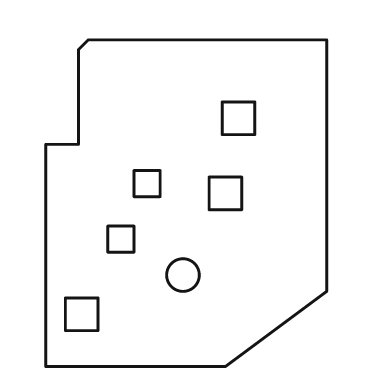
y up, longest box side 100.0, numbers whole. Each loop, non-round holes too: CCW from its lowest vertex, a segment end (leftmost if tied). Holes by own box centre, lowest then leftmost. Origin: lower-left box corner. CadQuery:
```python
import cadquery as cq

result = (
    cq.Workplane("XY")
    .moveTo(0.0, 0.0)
    .lineTo(55.0, 0.0)
    .lineTo(86.0, 23.0)
    .lineTo(86.0, 100.0)
    .lineTo(13.0, 100.0)
    .lineTo(10.0, 97.0)
    .lineTo(10.0, 68.0)
    .lineTo(0.0, 68.0)
    .close()
    .moveTo(6.0, 11.0)
    .lineTo(16.0, 11.0)
    .lineTo(16.0, 21.0)
    .lineTo(6.0, 21.0)
    .close()
    .moveTo(42.0, 28.0)
    .circle(5.0)
    .moveTo(19.0, 35.0)
    .lineTo(27.0, 35.0)
    .lineTo(27.0, 43.0)
    .lineTo(19.0, 43.0)
    .close()
    .moveTo(50.0, 48.0)
    .lineTo(60.0, 48.0)
    .lineTo(60.0, 58.0)
    .lineTo(50.0, 58.0)
    .close()
    .moveTo(27.0, 52.0)
    .lineTo(35.0, 52.0)
    .lineTo(35.0, 60.0)
    .lineTo(27.0, 60.0)
    .close()
    .moveTo(54.0, 71.0)
    .lineTo(64.0, 71.0)
    .lineTo(64.0, 81.0)
    .lineTo(54.0, 81.0)
    .close()
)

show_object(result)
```